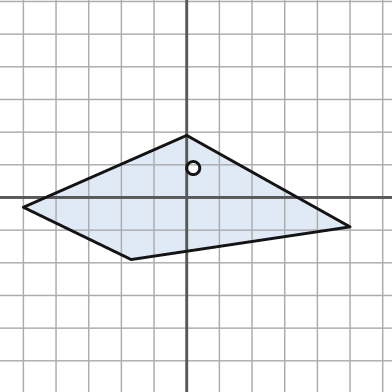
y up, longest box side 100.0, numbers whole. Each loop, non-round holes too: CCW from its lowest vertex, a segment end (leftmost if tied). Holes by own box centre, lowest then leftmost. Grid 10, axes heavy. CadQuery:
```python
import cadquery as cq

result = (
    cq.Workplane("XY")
    .moveTo(-17.0, -19.0)
    .lineTo(50.0, -9.0)
    .lineTo(0.0, 19.0)
    .lineTo(-50.0, -3.0)
    .close()
    .moveTo(2.0, 9.0)
    .circle(2.0)
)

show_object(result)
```